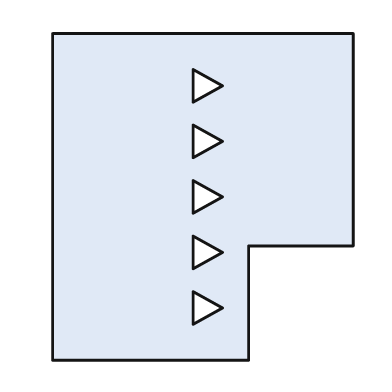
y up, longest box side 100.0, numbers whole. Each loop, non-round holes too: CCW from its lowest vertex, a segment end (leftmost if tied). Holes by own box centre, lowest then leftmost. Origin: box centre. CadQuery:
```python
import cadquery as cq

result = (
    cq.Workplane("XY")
    .moveTo(-46.0, -50.0)
    .lineTo(14.0, -50.0)
    .lineTo(14.0, -15.0)
    .lineTo(46.0, -15.0)
    .lineTo(46.0, 50.0)
    .lineTo(-46.0, 50.0)
    .close()
    .moveTo(-3.0, -39.0)
    .lineTo(6.0, -34.0)
    .lineTo(-3.0, -29.0)
    .close()
    .moveTo(-3.0, -22.0)
    .lineTo(6.0, -17.0)
    .lineTo(-3.0, -12.0)
    .close()
    .moveTo(-3.0, -5.0)
    .lineTo(6.0, 0.0)
    .lineTo(-3.0, 5.0)
    .close()
    .moveTo(-3.0, 12.0)
    .lineTo(6.0, 17.0)
    .lineTo(-3.0, 22.0)
    .close()
    .moveTo(-3.0, 29.0)
    .lineTo(6.0, 34.0)
    .lineTo(-3.0, 39.0)
    .close()
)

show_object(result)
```